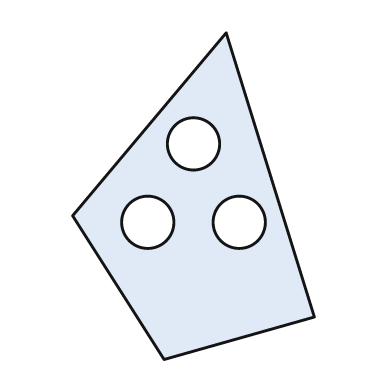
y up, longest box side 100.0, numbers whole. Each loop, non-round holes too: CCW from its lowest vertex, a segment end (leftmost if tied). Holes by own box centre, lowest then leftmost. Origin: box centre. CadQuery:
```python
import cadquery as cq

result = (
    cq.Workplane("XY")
    .moveTo(-9.0, -50.0)
    .lineTo(37.0, -37.0)
    .lineTo(10.0, 50.0)
    .lineTo(-37.0, -6.0)
    .close()
    .moveTo(-14.0, -8.0)
    .circle(8.0)
    .moveTo(14.0, -8.0)
    .circle(8.0)
    .moveTo(0.0, 16.0)
    .circle(8.0)
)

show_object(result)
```